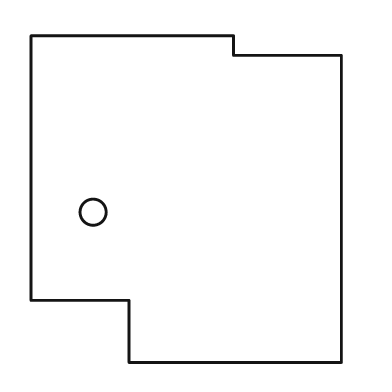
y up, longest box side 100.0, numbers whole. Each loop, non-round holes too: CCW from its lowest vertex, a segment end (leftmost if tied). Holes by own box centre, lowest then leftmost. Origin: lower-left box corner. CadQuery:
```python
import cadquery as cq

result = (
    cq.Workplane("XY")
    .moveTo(30.0, 0.0)
    .lineTo(95.0, 0.0)
    .lineTo(95.0, 94.0)
    .lineTo(62.0, 94.0)
    .lineTo(62.0, 100.0)
    .lineTo(0.0, 100.0)
    .lineTo(0.0, 19.0)
    .lineTo(30.0, 19.0)
    .close()
    .moveTo(19.0, 46.0)
    .circle(4.0)
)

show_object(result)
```